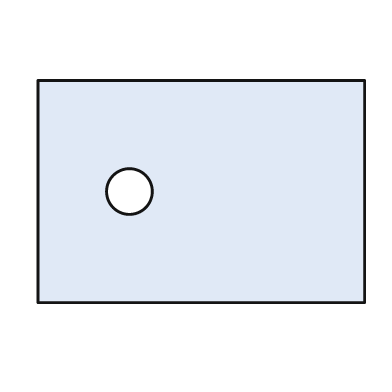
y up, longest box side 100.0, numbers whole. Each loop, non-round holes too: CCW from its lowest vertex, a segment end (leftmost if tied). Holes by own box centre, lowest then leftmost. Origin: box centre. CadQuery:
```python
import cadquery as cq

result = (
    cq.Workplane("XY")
    .moveTo(-50.0, -34.0)
    .lineTo(50.0, -34.0)
    .lineTo(50.0, 34.0)
    .lineTo(-50.0, 34.0)
    .close()
    .moveTo(-22.0, 0.0)
    .circle(7.0)
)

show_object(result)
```